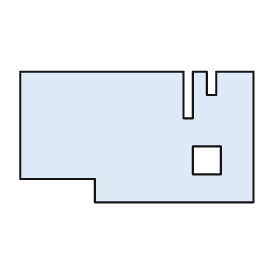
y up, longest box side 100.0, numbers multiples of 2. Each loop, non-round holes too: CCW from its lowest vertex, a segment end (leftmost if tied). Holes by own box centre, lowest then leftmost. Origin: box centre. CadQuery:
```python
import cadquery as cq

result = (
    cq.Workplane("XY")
    .moveTo(-18.0, -28.0)
    .lineTo(50.0, -28.0)
    .lineTo(50.0, 28.0)
    .lineTo(34.0, 28.0)
    .lineTo(34.0, 18.0)
    .lineTo(30.0, 18.0)
    .lineTo(30.0, 28.0)
    .lineTo(24.0, 28.0)
    .lineTo(24.0, 8.0)
    .lineTo(20.0, 8.0)
    .lineTo(20.0, 28.0)
    .lineTo(-50.0, 28.0)
    .lineTo(-50.0, -18.0)
    .lineTo(-18.0, -18.0)
    .close()
    .moveTo(24.0, -16.0)
    .lineTo(36.0, -16.0)
    .lineTo(36.0, -4.0)
    .lineTo(24.0, -4.0)
    .close()
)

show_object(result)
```